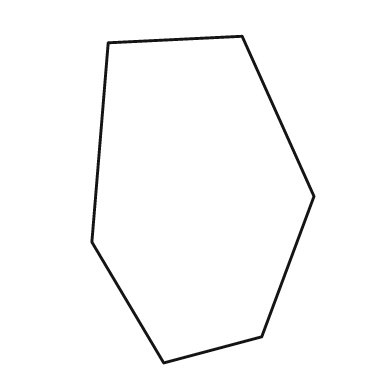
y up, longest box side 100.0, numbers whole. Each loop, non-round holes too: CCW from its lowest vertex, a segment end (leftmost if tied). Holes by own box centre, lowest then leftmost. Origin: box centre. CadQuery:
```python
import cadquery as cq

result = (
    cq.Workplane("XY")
    .moveTo(-12.0, -50.0)
    .lineTo(18.0, -42.0)
    .lineTo(34.0, 1.0)
    .lineTo(12.0, 50.0)
    .lineTo(-29.0, 48.0)
    .lineTo(-34.0, -13.0)
    .close()
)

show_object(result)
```